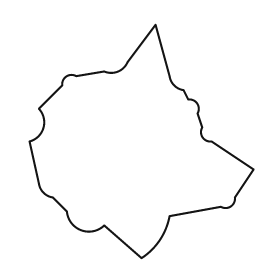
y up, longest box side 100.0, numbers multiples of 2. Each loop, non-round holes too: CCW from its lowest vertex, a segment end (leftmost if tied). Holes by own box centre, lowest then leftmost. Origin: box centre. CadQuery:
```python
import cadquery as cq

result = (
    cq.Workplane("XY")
    .moveTo(0.0, -50.0)
    .threePointArc((8.0, -42.0), (12.0, -32.0))
    .lineTo(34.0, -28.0)
    .threePointArc((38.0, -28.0), (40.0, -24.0))
    .lineTo(48.0, -12.0)
    .lineTo(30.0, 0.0)
    .threePointArc((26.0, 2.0), (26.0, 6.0))
    .lineTo(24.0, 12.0)
    .threePointArc((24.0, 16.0), (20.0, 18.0))
    .lineTo(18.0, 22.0)
    .threePointArc((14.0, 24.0), (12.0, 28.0))
    .lineTo(6.0, 50.0)
    .lineTo(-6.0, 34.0)
    .threePointArc((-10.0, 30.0), (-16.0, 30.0))
    .lineTo(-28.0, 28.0)
    .threePointArc((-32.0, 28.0), (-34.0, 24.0))
    .lineTo(-44.0, 14.0)
    .threePointArc((-42.0, 6.0), (-48.0, 0.0))
    .lineTo(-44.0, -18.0)
    .threePointArc((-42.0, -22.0), (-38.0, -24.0))
    .lineTo(-32.0, -30.0)
    .threePointArc((-26.0, -38.0), (-16.0, -36.0))
    .close()
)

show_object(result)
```